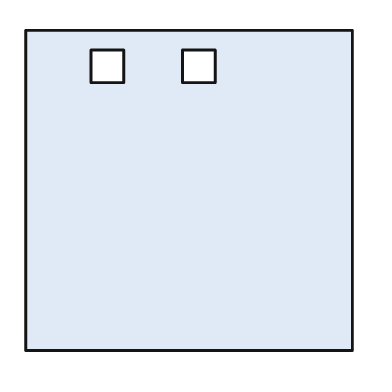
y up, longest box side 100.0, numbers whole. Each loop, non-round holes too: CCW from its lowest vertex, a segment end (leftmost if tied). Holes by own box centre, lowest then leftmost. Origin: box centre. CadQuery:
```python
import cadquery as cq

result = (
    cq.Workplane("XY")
    .moveTo(-50.0, -49.0)
    .lineTo(50.0, -49.0)
    .lineTo(50.0, 49.0)
    .lineTo(-50.0, 49.0)
    .close()
    .moveTo(-30.0, 33.0)
    .lineTo(-20.0, 33.0)
    .lineTo(-20.0, 43.0)
    .lineTo(-30.0, 43.0)
    .close()
    .moveTo(-2.0, 33.0)
    .lineTo(8.0, 33.0)
    .lineTo(8.0, 43.0)
    .lineTo(-2.0, 43.0)
    .close()
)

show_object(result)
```